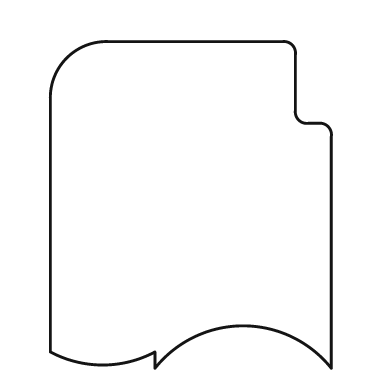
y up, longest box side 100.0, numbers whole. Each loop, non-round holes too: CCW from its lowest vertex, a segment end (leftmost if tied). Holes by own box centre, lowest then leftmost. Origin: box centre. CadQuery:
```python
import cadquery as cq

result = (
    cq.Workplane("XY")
    .moveTo(-11.0, -50.0)
    .threePointArc((16.0, -37.0), (43.0, -50.0))
    .lineTo(43.0, 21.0)
    .threePointArc((42.0, 24.0), (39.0, 25.0))
    .lineTo(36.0, 25.0)
    .threePointArc((33.0, 26.0), (32.0, 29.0))
    .lineTo(32.0, 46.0)
    .threePointArc((31.0, 49.0), (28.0, 50.0))
    .lineTo(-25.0, 50.0)
    .threePointArc((-38.0, 45.0), (-43.0, 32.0))
    .lineTo(-43.0, -45.0)
    .threePointArc((-27.0, -49.0), (-11.0, -45.0))
    .close()
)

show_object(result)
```